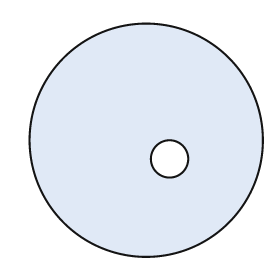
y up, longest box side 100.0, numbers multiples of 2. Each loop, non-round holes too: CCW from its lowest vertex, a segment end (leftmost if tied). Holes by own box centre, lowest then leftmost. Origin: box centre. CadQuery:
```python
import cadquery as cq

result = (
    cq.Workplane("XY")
    .moveTo(0.0, 0.0)
    .circle(50.0)
    .moveTo(10.0, -8.0)
    .circle(8.0)
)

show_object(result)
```